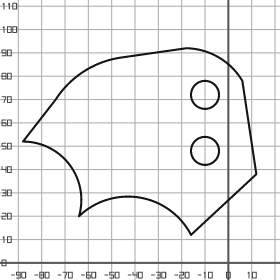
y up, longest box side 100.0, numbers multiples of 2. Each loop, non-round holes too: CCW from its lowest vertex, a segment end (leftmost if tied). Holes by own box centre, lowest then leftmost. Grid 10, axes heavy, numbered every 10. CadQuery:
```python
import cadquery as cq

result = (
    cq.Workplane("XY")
    .moveTo(-16.0, 12.0)
    .lineTo(12.0, 38.0)
    .lineTo(6.0, 78.0)
    .threePointArc((-4.0, 88.0), (-18.0, 92.0))
    .lineTo(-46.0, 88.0)
    .threePointArc((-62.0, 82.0), (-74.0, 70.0))
    .lineTo(-88.0, 52.0)
    .threePointArc((-68.0, 42.0), (-64.0, 20.0))
    .threePointArc((-38.0, 28.0), (-16.0, 12.0))
    .close()
    .moveTo(-10.0, 48.0)
    .circle(6.0)
    .moveTo(-10.0, 72.0)
    .circle(6.0)
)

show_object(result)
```